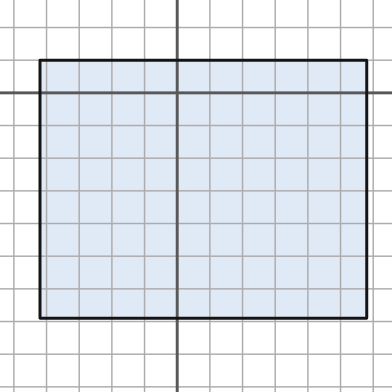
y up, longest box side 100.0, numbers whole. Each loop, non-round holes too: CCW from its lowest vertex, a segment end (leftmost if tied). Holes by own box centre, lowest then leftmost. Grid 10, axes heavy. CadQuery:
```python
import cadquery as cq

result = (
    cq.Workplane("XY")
    .moveTo(-42.0, -69.0)
    .lineTo(58.0, -69.0)
    .lineTo(58.0, 10.0)
    .lineTo(-42.0, 10.0)
    .close()
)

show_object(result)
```